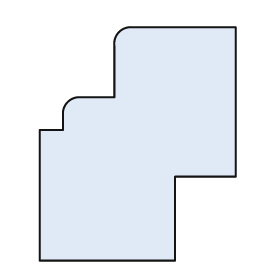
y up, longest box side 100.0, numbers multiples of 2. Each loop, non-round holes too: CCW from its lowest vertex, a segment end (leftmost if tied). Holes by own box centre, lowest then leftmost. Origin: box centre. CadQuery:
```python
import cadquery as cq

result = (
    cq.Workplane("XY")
    .moveTo(-42.0, -50.0)
    .lineTo(16.0, -50.0)
    .lineTo(16.0, -14.0)
    .lineTo(42.0, -14.0)
    .lineTo(42.0, 50.0)
    .lineTo(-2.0, 50.0)
    .threePointArc((-8.0, 48.0), (-10.0, 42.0))
    .lineTo(-10.0, 20.0)
    .lineTo(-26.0, 20.0)
    .threePointArc((-30.0, 18.0), (-32.0, 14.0))
    .lineTo(-32.0, 6.0)
    .lineTo(-42.0, 6.0)
    .close()
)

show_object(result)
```